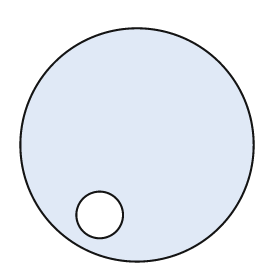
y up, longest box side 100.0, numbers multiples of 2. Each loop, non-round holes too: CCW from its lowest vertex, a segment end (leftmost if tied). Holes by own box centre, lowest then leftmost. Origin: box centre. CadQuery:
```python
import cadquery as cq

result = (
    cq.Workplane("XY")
    .moveTo(0.0, 0.0)
    .circle(50.0)
    .moveTo(-16.0, -30.0)
    .circle(10.0)
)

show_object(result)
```